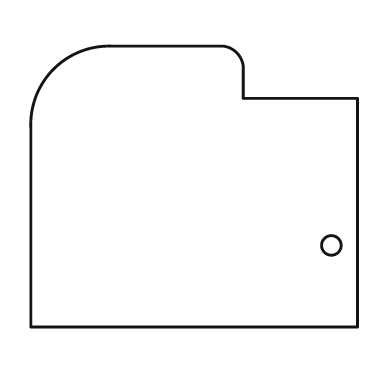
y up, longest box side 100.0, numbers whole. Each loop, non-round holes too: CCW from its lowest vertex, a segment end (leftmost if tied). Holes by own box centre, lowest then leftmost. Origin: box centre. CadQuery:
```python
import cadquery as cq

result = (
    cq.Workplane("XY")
    .moveTo(-50.0, -43.0)
    .lineTo(50.0, -43.0)
    .lineTo(50.0, 27.0)
    .lineTo(15.0, 27.0)
    .lineTo(15.0, 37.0)
    .threePointArc((13.0, 41.0), (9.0, 43.0))
    .lineTo(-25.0, 43.0)
    .threePointArc((-43.0, 36.0), (-50.0, 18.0))
    .close()
    .moveTo(42.0, -18.0)
    .circle(3.0)
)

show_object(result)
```